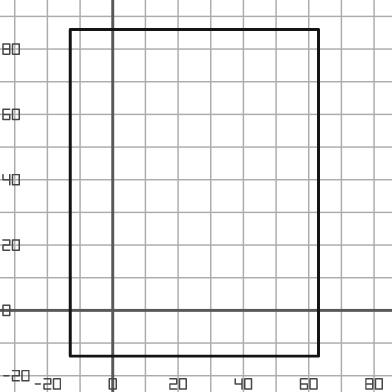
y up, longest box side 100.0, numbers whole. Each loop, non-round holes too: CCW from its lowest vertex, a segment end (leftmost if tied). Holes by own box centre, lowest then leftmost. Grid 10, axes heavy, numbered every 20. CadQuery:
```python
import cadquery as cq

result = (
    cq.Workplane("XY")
    .moveTo(-13.0, -14.0)
    .lineTo(63.0, -14.0)
    .lineTo(63.0, 86.0)
    .lineTo(-13.0, 86.0)
    .close()
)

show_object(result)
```